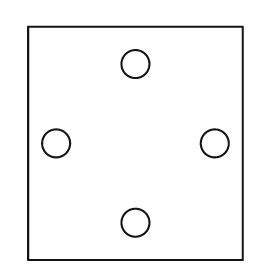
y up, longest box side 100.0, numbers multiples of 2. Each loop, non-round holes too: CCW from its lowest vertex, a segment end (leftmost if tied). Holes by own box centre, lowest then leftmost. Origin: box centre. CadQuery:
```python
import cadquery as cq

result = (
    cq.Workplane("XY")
    .moveTo(-46.0, -50.0)
    .lineTo(46.0, -50.0)
    .lineTo(46.0, 50.0)
    .lineTo(-46.0, 50.0)
    .close()
    .moveTo(0.0, -34.0)
    .circle(6.0)
    .moveTo(-34.0, 0.0)
    .circle(6.0)
    .moveTo(34.0, 0.0)
    .circle(6.0)
    .moveTo(0.0, 34.0)
    .circle(6.0)
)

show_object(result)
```